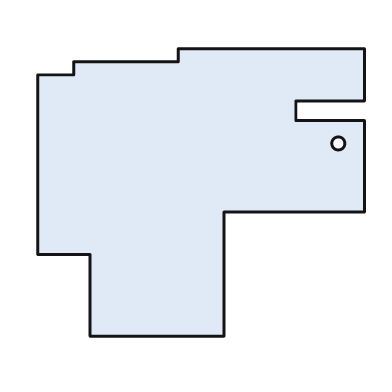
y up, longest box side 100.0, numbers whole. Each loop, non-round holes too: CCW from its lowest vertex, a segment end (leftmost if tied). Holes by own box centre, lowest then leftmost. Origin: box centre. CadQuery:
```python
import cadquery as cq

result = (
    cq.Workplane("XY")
    .moveTo(-34.0, -44.0)
    .lineTo(7.0, -44.0)
    .lineTo(7.0, -6.0)
    .lineTo(50.0, -6.0)
    .lineTo(50.0, 22.0)
    .lineTo(29.0, 22.0)
    .lineTo(29.0, 28.0)
    .lineTo(50.0, 28.0)
    .lineTo(50.0, 44.0)
    .lineTo(-7.0, 44.0)
    .lineTo(-7.0, 40.0)
    .lineTo(-39.0, 40.0)
    .lineTo(-39.0, 36.0)
    .lineTo(-50.0, 36.0)
    .lineTo(-50.0, -19.0)
    .lineTo(-34.0, -19.0)
    .close()
    .moveTo(42.0, 15.0)
    .circle(2.0)
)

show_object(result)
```